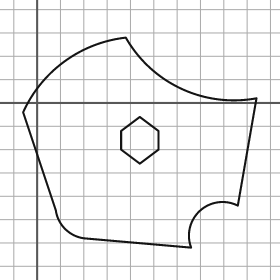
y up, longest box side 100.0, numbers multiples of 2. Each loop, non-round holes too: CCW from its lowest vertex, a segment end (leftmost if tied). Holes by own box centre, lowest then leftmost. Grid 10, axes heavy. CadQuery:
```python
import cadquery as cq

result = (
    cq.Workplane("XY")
    .moveTo(66.0, -62.0)
    .threePointArc((70.0, -46.0), (86.0, -44.0))
    .lineTo(94.0, 2.0)
    .threePointArc((62.0, 6.0), (38.0, 28.0))
    .threePointArc((12.0, 18.0), (-6.0, -4.0))
    .lineTo(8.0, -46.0)
    .threePointArc((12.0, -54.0), (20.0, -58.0))
    .close()
    .moveTo(44.0, -26.0)
    .lineTo(52.0, -20.0)
    .lineTo(52.0, -12.0)
    .lineTo(44.0, -6.0)
    .lineTo(36.0, -12.0)
    .lineTo(36.0, -20.0)
    .close()
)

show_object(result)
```